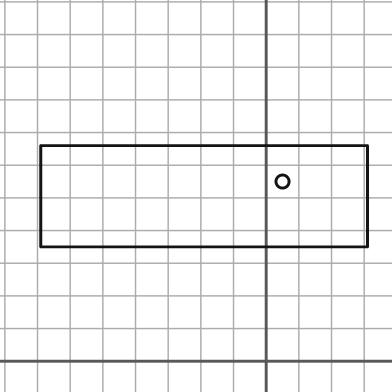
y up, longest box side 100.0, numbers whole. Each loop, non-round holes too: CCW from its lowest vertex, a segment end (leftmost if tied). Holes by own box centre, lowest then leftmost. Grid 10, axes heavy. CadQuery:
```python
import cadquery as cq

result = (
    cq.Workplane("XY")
    .moveTo(-69.0, 35.0)
    .lineTo(31.0, 35.0)
    .lineTo(31.0, 66.0)
    .lineTo(-69.0, 66.0)
    .close()
    .moveTo(5.0, 55.0)
    .circle(2.0)
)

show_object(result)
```